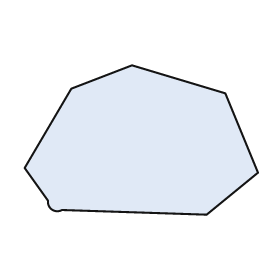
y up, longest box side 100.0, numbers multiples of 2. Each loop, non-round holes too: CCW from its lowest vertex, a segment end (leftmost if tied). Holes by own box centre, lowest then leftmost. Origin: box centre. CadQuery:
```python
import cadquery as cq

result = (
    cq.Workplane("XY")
    .moveTo(28.0, -32.0)
    .lineTo(50.0, -14.0)
    .lineTo(36.0, 20.0)
    .lineTo(-4.0, 32.0)
    .lineTo(-30.0, 22.0)
    .lineTo(-50.0, -12.0)
    .lineTo(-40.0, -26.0)
    .threePointArc((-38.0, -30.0), (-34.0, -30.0))
    .close()
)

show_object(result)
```